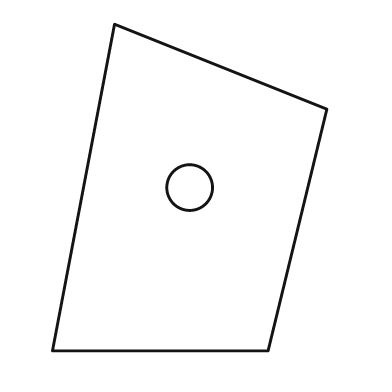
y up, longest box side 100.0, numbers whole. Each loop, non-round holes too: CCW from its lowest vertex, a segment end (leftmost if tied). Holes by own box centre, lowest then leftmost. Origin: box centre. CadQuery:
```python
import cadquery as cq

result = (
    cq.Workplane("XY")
    .moveTo(-42.0, -50.0)
    .lineTo(24.0, -50.0)
    .lineTo(42.0, 24.0)
    .lineTo(-23.0, 50.0)
    .close()
    .moveTo(0.0, 0.0)
    .circle(7.0)
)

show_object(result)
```